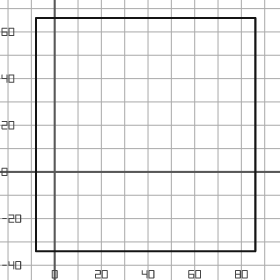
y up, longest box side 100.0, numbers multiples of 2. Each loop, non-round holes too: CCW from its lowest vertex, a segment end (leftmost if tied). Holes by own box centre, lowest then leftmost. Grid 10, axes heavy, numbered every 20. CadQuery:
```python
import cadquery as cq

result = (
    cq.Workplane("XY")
    .moveTo(-8.0, -34.0)
    .lineTo(86.0, -34.0)
    .lineTo(86.0, 66.0)
    .lineTo(-8.0, 66.0)
    .close()
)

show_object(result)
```